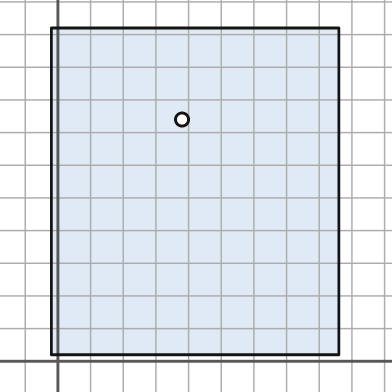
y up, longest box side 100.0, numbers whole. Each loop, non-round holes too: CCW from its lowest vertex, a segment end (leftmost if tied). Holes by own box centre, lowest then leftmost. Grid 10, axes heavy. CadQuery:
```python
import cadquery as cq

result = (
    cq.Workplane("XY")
    .moveTo(-2.0, 2.0)
    .lineTo(86.0, 2.0)
    .lineTo(86.0, 102.0)
    .lineTo(-2.0, 102.0)
    .close()
    .moveTo(38.0, 74.0)
    .circle(2.0)
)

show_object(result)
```